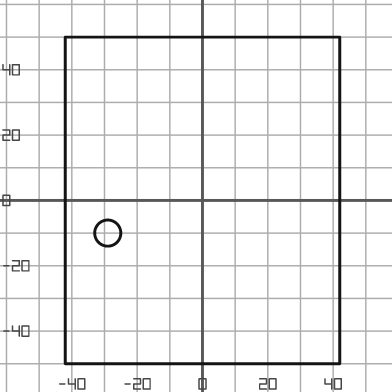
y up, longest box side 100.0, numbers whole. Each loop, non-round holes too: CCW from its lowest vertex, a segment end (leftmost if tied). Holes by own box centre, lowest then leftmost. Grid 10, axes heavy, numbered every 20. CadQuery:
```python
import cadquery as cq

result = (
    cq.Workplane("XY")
    .moveTo(-42.0, -50.0)
    .lineTo(42.0, -50.0)
    .lineTo(42.0, 50.0)
    .lineTo(-42.0, 50.0)
    .close()
    .moveTo(-29.0, -10.0)
    .circle(4.0)
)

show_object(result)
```